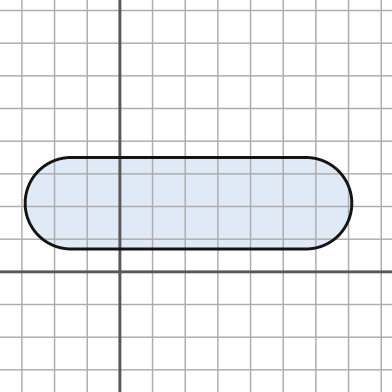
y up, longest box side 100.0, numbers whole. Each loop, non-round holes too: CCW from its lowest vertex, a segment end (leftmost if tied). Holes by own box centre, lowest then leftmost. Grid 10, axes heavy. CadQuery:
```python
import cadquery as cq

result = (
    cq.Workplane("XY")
    .moveTo(-15.0, 7.0)
    .lineTo(57.0, 7.0)
    .threePointArc((71.0, 21.0), (57.0, 35.0))
    .lineTo(-15.0, 35.0)
    .threePointArc((-29.0, 21.0), (-15.0, 7.0))
    .close()
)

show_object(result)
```